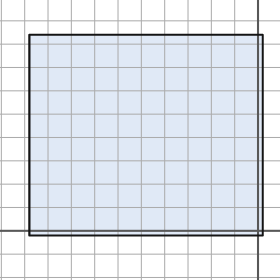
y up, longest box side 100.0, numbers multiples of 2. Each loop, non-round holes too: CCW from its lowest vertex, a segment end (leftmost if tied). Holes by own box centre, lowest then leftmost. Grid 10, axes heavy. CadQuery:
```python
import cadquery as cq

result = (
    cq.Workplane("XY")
    .moveTo(-98.0, -2.0)
    .lineTo(2.0, -2.0)
    .lineTo(2.0, 84.0)
    .lineTo(-98.0, 84.0)
    .close()
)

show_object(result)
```